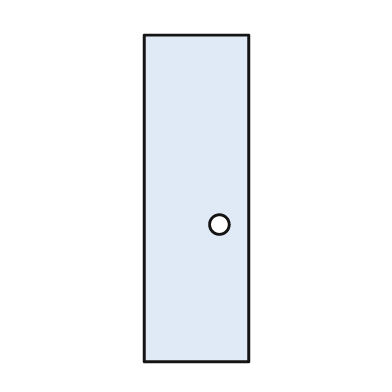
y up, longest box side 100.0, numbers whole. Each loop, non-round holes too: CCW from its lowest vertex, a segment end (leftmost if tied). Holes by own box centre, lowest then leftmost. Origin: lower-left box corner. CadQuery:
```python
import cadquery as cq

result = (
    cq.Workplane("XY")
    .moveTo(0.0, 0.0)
    .lineTo(32.0, 0.0)
    .lineTo(32.0, 100.0)
    .lineTo(0.0, 100.0)
    .close()
    .moveTo(23.0, 42.0)
    .circle(3.0)
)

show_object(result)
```